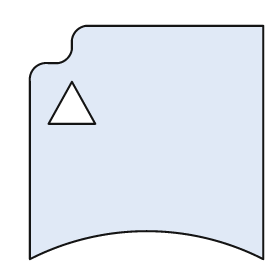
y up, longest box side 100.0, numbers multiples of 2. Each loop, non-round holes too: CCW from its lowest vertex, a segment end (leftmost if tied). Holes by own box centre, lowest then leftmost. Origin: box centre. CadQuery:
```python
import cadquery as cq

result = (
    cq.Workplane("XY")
    .moveTo(-50.0, -50.0)
    .threePointArc((0.0, -38.0), (50.0, -50.0))
    .lineTo(50.0, 50.0)
    .lineTo(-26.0, 50.0)
    .threePointArc((-30.0, 48.0), (-32.0, 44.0))
    .lineTo(-32.0, 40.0)
    .threePointArc((-34.0, 36.0), (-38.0, 34.0))
    .lineTo(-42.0, 34.0)
    .threePointArc((-48.0, 32.0), (-50.0, 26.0))
    .close()
    .moveTo(-42.0, 8.0)
    .lineTo(-22.0, 8.0)
    .lineTo(-32.0, 26.0)
    .close()
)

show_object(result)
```